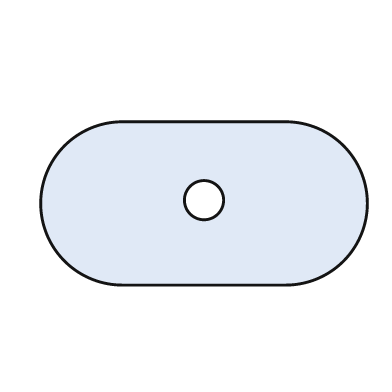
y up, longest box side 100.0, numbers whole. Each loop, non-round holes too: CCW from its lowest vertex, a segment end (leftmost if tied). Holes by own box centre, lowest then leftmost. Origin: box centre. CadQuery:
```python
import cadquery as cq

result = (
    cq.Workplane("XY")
    .moveTo(-25.0, -25.0)
    .lineTo(25.0, -25.0)
    .threePointArc((50.0, 0.0), (25.0, 25.0))
    .lineTo(-25.0, 25.0)
    .threePointArc((-50.0, 0.0), (-25.0, -25.0))
    .close()
    .moveTo(0.0, 1.0)
    .circle(6.0)
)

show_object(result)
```